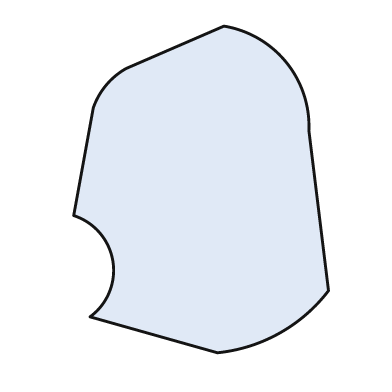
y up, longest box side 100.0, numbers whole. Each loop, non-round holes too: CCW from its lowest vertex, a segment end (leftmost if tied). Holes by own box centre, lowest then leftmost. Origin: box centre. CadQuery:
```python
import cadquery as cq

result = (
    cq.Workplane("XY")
    .moveTo(5.0, -50.0)
    .threePointArc((24.0, -44.0), (39.0, -31.0))
    .lineTo(33.0, 18.0)
    .threePointArc((26.0, 39.0), (7.0, 50.0))
    .lineTo(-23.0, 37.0)
    .threePointArc((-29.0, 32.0), (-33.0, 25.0))
    .lineTo(-39.0, -8.0)
    .threePointArc((-27.0, -22.0), (-34.0, -39.0))
    .close()
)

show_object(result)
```